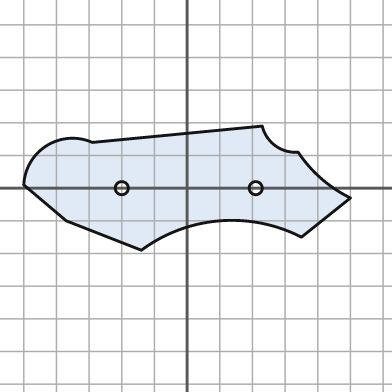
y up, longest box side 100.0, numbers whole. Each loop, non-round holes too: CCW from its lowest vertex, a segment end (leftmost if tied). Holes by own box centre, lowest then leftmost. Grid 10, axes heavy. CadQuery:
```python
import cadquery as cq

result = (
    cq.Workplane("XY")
    .moveTo(-14.0, -19.0)
    .threePointArc((10.0, -10.0), (35.0, -15.0))
    .lineTo(50.0, -3.0)
    .threePointArc((41.0, 3.0), (34.0, 11.0))
    .threePointArc((27.0, 13.0), (23.0, 19.0))
    .lineTo(-29.0, 14.0)
    .threePointArc((-43.0, 13.0), (-50.0, 1.0))
    .lineTo(-37.0, -10.0)
    .close()
    .moveTo(-20.0, 0.0)
    .circle(2.0)
    .moveTo(21.0, 0.0)
    .circle(2.0)
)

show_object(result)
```